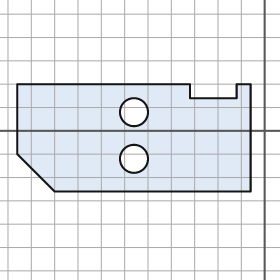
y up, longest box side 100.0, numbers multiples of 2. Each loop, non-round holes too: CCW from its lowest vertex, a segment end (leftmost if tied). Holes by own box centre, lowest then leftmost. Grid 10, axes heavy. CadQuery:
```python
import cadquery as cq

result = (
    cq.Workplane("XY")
    .moveTo(-90.0, -26.0)
    .lineTo(-6.0, -26.0)
    .lineTo(-6.0, 20.0)
    .lineTo(-12.0, 20.0)
    .lineTo(-12.0, 14.0)
    .lineTo(-32.0, 14.0)
    .lineTo(-32.0, 20.0)
    .lineTo(-106.0, 20.0)
    .lineTo(-106.0, -10.0)
    .close()
    .moveTo(-56.0, -12.0)
    .circle(6.0)
    .moveTo(-56.0, 8.0)
    .circle(6.0)
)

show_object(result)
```